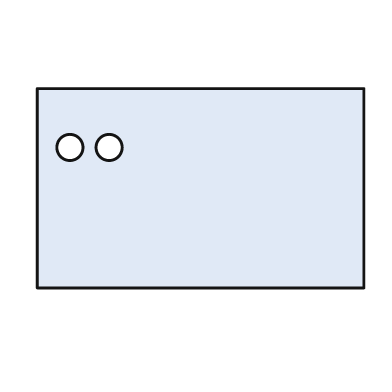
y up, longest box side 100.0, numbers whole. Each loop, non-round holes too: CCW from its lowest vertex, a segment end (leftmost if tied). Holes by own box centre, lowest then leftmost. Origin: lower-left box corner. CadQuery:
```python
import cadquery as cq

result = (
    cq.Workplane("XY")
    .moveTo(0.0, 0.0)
    .lineTo(100.0, 0.0)
    .lineTo(100.0, 61.0)
    .lineTo(0.0, 61.0)
    .close()
    .moveTo(10.0, 43.0)
    .circle(4.0)
    .moveTo(22.0, 43.0)
    .circle(4.0)
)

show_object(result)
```